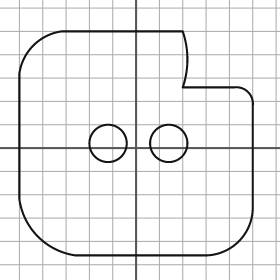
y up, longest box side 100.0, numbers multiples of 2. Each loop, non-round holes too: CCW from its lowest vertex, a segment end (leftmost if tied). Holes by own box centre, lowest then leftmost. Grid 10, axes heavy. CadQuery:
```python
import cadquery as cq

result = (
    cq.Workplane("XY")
    .moveTo(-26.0, -46.0)
    .lineTo(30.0, -46.0)
    .threePointArc((44.0, -40.0), (50.0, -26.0))
    .lineTo(50.0, 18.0)
    .threePointArc((48.0, 24.0), (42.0, 26.0))
    .lineTo(20.0, 26.0)
    .threePointArc((22.0, 38.0), (20.0, 50.0))
    .lineTo(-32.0, 50.0)
    .threePointArc((-44.0, 44.0), (-50.0, 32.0))
    .lineTo(-50.0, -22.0)
    .threePointArc((-42.0, -38.0), (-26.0, -46.0))
    .close()
    .moveTo(-12.0, 2.0)
    .circle(8.0)
    .moveTo(14.0, 2.0)
    .circle(8.0)
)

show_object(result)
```